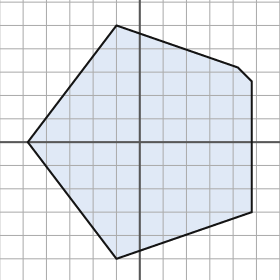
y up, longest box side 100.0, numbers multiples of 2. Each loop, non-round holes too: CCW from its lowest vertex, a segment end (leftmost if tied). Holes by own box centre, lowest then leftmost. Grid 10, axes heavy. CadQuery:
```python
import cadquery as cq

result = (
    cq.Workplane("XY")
    .moveTo(-10.0, -50.0)
    .lineTo(48.0, -30.0)
    .lineTo(48.0, 26.0)
    .lineTo(42.0, 32.0)
    .lineTo(-10.0, 50.0)
    .lineTo(-48.0, 0.0)
    .close()
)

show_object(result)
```